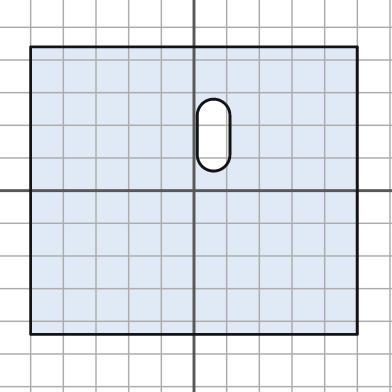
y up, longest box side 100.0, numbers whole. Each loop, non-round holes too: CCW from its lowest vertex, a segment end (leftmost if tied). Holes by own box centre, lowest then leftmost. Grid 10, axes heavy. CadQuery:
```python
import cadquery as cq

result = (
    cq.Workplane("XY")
    .moveTo(-50.0, -44.0)
    .lineTo(50.0, -44.0)
    .lineTo(50.0, 44.0)
    .lineTo(-50.0, 44.0)
    .close()
    .moveTo(1.0, 11.0)
    .threePointArc((6.0, 6.0), (11.0, 11.0))
    .lineTo(11.0, 23.0)
    .threePointArc((6.0, 28.0), (1.0, 23.0))
    .close()
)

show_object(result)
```